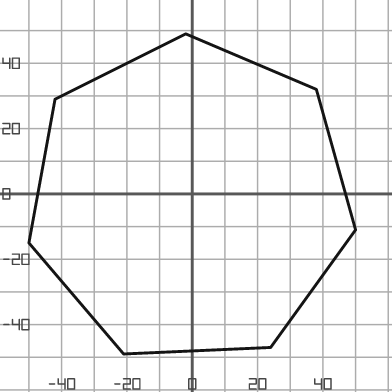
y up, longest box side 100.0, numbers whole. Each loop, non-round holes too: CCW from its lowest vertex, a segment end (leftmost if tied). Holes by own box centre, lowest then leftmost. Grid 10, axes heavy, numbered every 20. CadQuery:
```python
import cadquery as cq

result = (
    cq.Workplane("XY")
    .moveTo(-21.0, -49.0)
    .lineTo(24.0, -47.0)
    .lineTo(50.0, -11.0)
    .lineTo(38.0, 32.0)
    .lineTo(-2.0, 49.0)
    .lineTo(-42.0, 29.0)
    .lineTo(-50.0, -15.0)
    .close()
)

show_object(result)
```